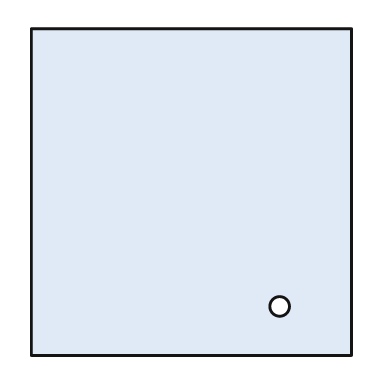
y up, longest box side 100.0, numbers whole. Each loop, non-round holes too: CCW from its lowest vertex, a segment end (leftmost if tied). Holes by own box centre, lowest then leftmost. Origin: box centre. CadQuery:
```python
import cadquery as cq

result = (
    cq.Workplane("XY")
    .moveTo(-49.0, -50.0)
    .lineTo(49.0, -50.0)
    .lineTo(49.0, 50.0)
    .lineTo(-49.0, 50.0)
    .close()
    .moveTo(27.0, -35.0)
    .circle(3.0)
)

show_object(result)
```